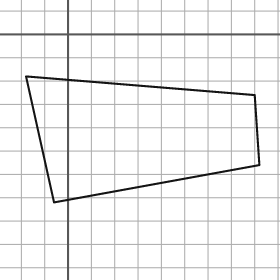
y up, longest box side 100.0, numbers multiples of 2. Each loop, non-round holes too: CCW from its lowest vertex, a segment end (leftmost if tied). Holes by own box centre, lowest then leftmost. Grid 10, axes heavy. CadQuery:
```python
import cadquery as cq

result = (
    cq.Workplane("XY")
    .moveTo(-6.0, -72.0)
    .lineTo(82.0, -56.0)
    .lineTo(80.0, -26.0)
    .lineTo(-18.0, -18.0)
    .close()
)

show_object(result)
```